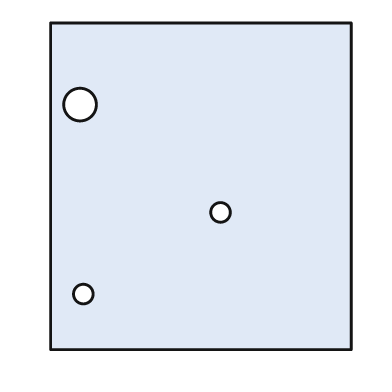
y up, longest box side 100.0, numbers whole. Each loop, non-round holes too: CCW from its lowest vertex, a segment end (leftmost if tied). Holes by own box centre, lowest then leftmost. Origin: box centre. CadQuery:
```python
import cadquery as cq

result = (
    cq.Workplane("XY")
    .moveTo(-46.0, -50.0)
    .lineTo(46.0, -50.0)
    .lineTo(46.0, 50.0)
    .lineTo(-46.0, 50.0)
    .close()
    .moveTo(-36.0, -33.0)
    .circle(3.0)
    .moveTo(6.0, -8.0)
    .circle(3.0)
    .moveTo(-37.0, 25.0)
    .circle(5.0)
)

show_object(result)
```